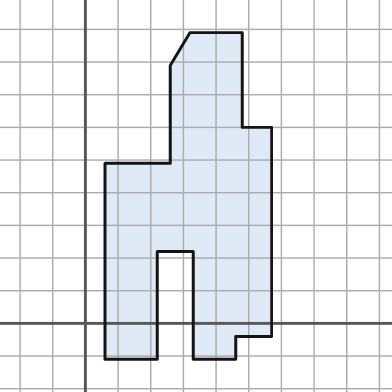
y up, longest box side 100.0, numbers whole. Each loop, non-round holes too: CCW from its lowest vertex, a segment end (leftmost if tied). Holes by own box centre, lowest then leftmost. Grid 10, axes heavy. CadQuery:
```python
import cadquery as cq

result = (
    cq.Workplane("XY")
    .moveTo(6.0, -11.0)
    .lineTo(22.0, -11.0)
    .lineTo(22.0, 22.0)
    .lineTo(33.0, 22.0)
    .lineTo(33.0, -11.0)
    .lineTo(46.0, -11.0)
    .lineTo(46.0, -4.0)
    .lineTo(57.0, -4.0)
    .lineTo(57.0, 60.0)
    .lineTo(48.0, 60.0)
    .lineTo(48.0, 89.0)
    .lineTo(32.0, 89.0)
    .lineTo(26.0, 79.0)
    .lineTo(26.0, 49.0)
    .lineTo(6.0, 49.0)
    .close()
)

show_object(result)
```